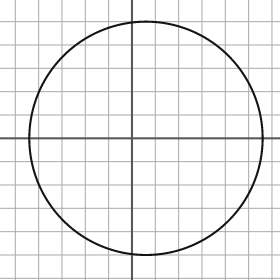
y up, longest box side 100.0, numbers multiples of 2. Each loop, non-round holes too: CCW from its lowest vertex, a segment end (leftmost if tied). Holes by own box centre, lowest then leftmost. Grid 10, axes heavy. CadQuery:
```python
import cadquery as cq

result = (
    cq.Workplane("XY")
    .moveTo(6.0, 0.0)
    .circle(50.0)
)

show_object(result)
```